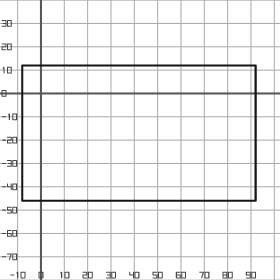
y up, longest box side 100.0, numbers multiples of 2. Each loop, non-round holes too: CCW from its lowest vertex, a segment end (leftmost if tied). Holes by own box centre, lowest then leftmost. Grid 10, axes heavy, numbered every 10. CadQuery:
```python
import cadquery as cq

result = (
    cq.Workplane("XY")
    .moveTo(-8.0, -46.0)
    .lineTo(92.0, -46.0)
    .lineTo(92.0, 12.0)
    .lineTo(-8.0, 12.0)
    .close()
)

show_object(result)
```